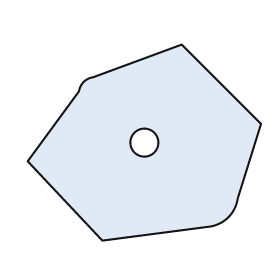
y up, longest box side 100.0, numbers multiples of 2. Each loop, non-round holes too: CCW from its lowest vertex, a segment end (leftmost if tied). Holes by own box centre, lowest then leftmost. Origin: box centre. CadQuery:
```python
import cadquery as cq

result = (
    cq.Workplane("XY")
    .moveTo(-18.0, -42.0)
    .lineTo(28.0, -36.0)
    .threePointArc((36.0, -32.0), (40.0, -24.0))
    .lineTo(50.0, 8.0)
    .lineTo(16.0, 42.0)
    .lineTo(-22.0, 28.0)
    .threePointArc((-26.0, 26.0), (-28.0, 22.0))
    .lineTo(-50.0, -8.0)
    .close()
    .moveTo(0.0, 0.0)
    .circle(6.0)
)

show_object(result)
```